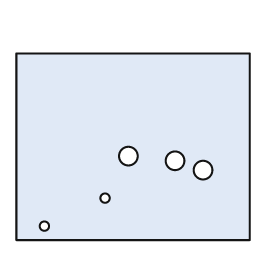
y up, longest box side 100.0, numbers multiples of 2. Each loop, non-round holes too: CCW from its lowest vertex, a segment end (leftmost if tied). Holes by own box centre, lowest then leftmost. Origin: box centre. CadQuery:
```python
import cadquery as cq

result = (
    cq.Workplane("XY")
    .moveTo(-50.0, -40.0)
    .lineTo(50.0, -40.0)
    .lineTo(50.0, 40.0)
    .lineTo(-50.0, 40.0)
    .close()
    .moveTo(-38.0, -34.0)
    .circle(2.0)
    .moveTo(-12.0, -22.0)
    .circle(2.0)
    .moveTo(30.0, -10.0)
    .circle(4.0)
    .moveTo(18.0, -6.0)
    .circle(4.0)
    .moveTo(-2.0, -4.0)
    .circle(4.0)
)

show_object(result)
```